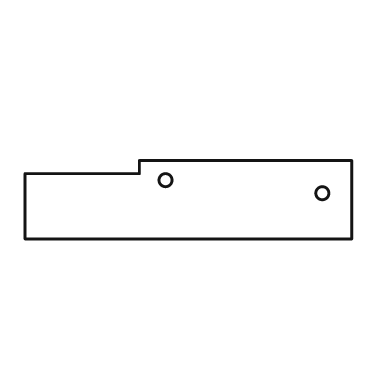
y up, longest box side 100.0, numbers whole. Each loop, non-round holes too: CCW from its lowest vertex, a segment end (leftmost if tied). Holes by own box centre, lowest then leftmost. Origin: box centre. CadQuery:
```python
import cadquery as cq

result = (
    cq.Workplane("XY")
    .moveTo(-50.0, -12.0)
    .lineTo(50.0, -12.0)
    .lineTo(50.0, 12.0)
    .lineTo(-15.0, 12.0)
    .lineTo(-15.0, 8.0)
    .lineTo(-50.0, 8.0)
    .close()
    .moveTo(41.0, 2.0)
    .circle(2.0)
    .moveTo(-7.0, 6.0)
    .circle(2.0)
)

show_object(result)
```